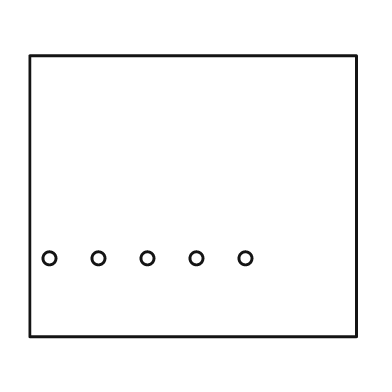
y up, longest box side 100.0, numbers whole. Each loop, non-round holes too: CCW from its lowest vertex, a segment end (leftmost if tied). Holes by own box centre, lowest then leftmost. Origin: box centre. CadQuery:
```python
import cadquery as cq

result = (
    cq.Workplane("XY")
    .moveTo(-50.0, -43.0)
    .lineTo(50.0, -43.0)
    .lineTo(50.0, 43.0)
    .lineTo(-50.0, 43.0)
    .close()
    .moveTo(-44.0, -19.0)
    .circle(2.0)
    .moveTo(-29.0, -19.0)
    .circle(2.0)
    .moveTo(-14.0, -19.0)
    .circle(2.0)
    .moveTo(1.0, -19.0)
    .circle(2.0)
    .moveTo(16.0, -19.0)
    .circle(2.0)
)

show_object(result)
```